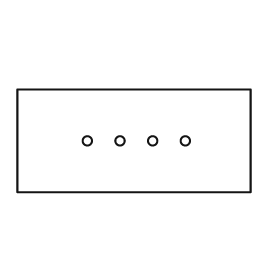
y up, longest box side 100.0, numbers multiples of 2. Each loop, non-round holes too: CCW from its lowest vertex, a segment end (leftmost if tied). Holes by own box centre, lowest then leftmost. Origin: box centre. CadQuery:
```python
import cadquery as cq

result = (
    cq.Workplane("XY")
    .moveTo(-50.0, -22.0)
    .lineTo(50.0, -22.0)
    .lineTo(50.0, 22.0)
    .lineTo(-50.0, 22.0)
    .close()
    .moveTo(-20.0, 0.0)
    .circle(2.0)
    .moveTo(-6.0, 0.0)
    .circle(2.0)
    .moveTo(8.0, 0.0)
    .circle(2.0)
    .moveTo(22.0, 0.0)
    .circle(2.0)
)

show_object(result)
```